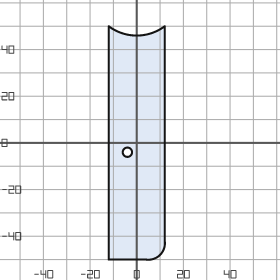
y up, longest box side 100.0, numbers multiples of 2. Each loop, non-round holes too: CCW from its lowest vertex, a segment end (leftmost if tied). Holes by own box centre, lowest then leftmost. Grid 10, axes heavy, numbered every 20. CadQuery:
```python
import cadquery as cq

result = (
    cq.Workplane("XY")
    .moveTo(-12.0, -50.0)
    .lineTo(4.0, -50.0)
    .threePointArc((10.0, -48.0), (12.0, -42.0))
    .lineTo(12.0, 50.0)
    .threePointArc((0.0, 46.0), (-12.0, 50.0))
    .close()
    .moveTo(-4.0, -4.0)
    .circle(2.0)
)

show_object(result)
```